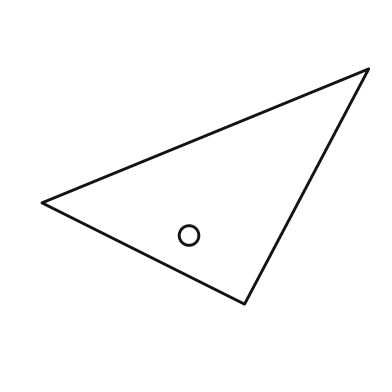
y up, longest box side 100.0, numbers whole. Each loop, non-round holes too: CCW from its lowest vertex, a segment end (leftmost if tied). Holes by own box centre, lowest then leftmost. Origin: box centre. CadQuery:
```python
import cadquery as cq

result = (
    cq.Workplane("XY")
    .moveTo(12.0, -36.0)
    .lineTo(50.0, 36.0)
    .lineTo(-50.0, -5.0)
    .close()
    .moveTo(-5.0, -15.0)
    .circle(3.0)
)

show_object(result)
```